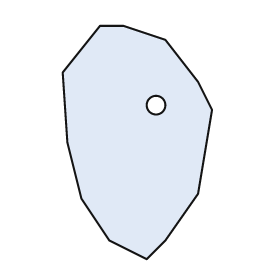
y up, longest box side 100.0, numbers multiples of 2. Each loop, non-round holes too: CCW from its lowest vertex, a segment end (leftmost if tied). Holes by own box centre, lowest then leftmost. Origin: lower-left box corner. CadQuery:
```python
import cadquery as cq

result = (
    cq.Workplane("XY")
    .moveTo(36.0, 0.0)
    .lineTo(44.0, 8.0)
    .lineTo(58.0, 28.0)
    .lineTo(64.0, 64.0)
    .lineTo(58.0, 76.0)
    .lineTo(44.0, 94.0)
    .lineTo(26.0, 100.0)
    .lineTo(16.0, 100.0)
    .lineTo(0.0, 80.0)
    .lineTo(2.0, 50.0)
    .lineTo(8.0, 26.0)
    .lineTo(20.0, 8.0)
    .close()
    .moveTo(40.0, 66.0)
    .circle(4.0)
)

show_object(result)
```